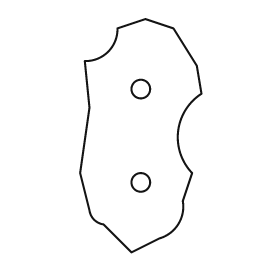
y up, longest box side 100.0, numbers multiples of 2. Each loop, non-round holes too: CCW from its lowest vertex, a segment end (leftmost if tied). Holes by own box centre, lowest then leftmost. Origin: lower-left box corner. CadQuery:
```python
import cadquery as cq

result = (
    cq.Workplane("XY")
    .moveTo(22.0, 0.0)
    .lineTo(34.0, 6.0)
    .threePointArc((42.0, 12.0), (44.0, 22.0))
    .lineTo(48.0, 34.0)
    .threePointArc((42.0, 52.0), (52.0, 68.0))
    .lineTo(50.0, 80.0)
    .lineTo(40.0, 96.0)
    .lineTo(28.0, 100.0)
    .lineTo(16.0, 96.0)
    .threePointArc((12.0, 86.0), (2.0, 82.0))
    .lineTo(4.0, 62.0)
    .lineTo(0.0, 34.0)
    .lineTo(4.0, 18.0)
    .threePointArc((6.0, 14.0), (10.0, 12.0))
    .close()
    .moveTo(26.0, 30.0)
    .circle(4.0)
    .moveTo(26.0, 70.0)
    .circle(4.0)
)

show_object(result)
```